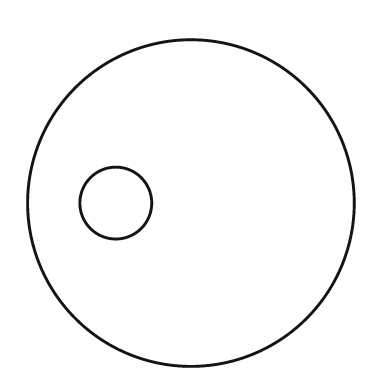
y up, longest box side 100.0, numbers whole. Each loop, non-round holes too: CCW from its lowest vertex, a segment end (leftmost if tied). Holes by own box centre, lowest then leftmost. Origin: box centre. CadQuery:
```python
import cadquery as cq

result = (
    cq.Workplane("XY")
    .moveTo(0.0, 0.0)
    .circle(50.0)
    .moveTo(-23.0, 0.0)
    .circle(11.0)
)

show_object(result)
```